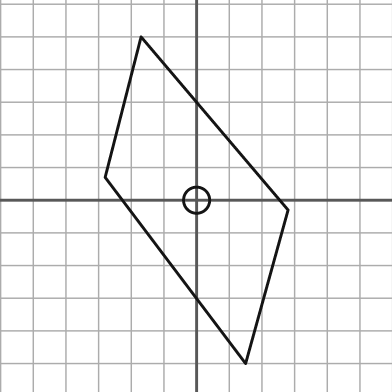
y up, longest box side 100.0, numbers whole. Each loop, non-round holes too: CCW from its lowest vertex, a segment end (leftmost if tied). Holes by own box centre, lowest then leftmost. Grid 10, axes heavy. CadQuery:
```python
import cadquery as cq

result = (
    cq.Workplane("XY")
    .moveTo(15.0, -50.0)
    .lineTo(28.0, -3.0)
    .lineTo(-17.0, 50.0)
    .lineTo(-28.0, 7.0)
    .close()
    .moveTo(0.0, 0.0)
    .circle(4.0)
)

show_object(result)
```